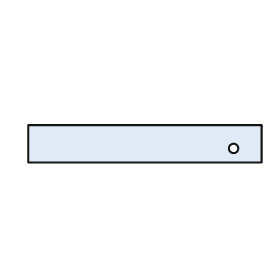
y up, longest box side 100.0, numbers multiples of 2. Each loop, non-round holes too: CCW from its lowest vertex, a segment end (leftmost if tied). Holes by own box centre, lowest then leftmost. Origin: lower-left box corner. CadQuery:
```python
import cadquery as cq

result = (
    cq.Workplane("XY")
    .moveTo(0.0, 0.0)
    .lineTo(100.0, 0.0)
    .lineTo(100.0, 16.0)
    .lineTo(0.0, 16.0)
    .close()
    .moveTo(88.0, 6.0)
    .circle(2.0)
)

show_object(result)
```